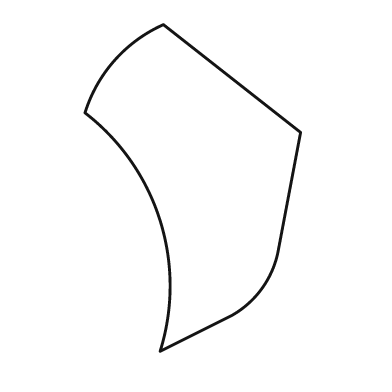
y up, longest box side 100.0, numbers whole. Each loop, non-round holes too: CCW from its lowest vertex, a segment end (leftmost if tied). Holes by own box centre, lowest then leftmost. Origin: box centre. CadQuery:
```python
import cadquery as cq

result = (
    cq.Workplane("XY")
    .moveTo(-10.0, -50.0)
    .lineTo(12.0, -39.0)
    .threePointArc((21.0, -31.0), (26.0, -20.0))
    .lineTo(33.0, 17.0)
    .lineTo(-9.0, 50.0)
    .threePointArc((-24.0, 39.0), (-33.0, 23.0))
    .threePointArc((-10.0, -10.0), (-10.0, -50.0))
    .close()
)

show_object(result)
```